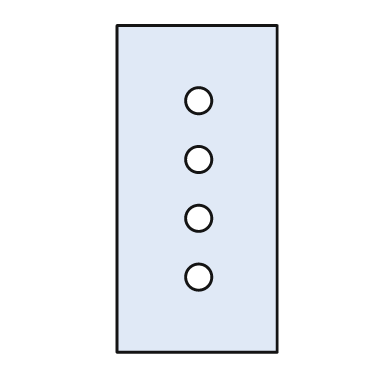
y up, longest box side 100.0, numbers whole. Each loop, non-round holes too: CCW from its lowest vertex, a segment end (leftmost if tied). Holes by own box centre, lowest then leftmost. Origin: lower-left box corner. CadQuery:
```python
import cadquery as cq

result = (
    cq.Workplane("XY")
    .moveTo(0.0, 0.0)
    .lineTo(49.0, 0.0)
    .lineTo(49.0, 100.0)
    .lineTo(0.0, 100.0)
    .close()
    .moveTo(25.0, 23.0)
    .circle(4.0)
    .moveTo(25.0, 41.0)
    .circle(4.0)
    .moveTo(25.0, 59.0)
    .circle(4.0)
    .moveTo(25.0, 77.0)
    .circle(4.0)
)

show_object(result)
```